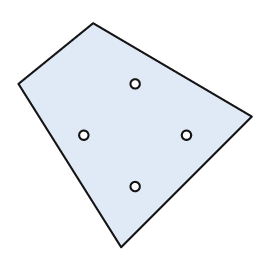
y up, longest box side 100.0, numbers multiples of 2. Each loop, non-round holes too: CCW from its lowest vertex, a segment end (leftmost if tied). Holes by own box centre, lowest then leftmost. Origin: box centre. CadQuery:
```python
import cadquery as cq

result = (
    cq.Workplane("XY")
    .moveTo(-6.0, -48.0)
    .lineTo(50.0, 8.0)
    .lineTo(-18.0, 48.0)
    .lineTo(-50.0, 22.0)
    .close()
    .moveTo(0.0, -22.0)
    .circle(2.0)
    .moveTo(-22.0, 0.0)
    .circle(2.0)
    .moveTo(22.0, 0.0)
    .circle(2.0)
    .moveTo(0.0, 22.0)
    .circle(2.0)
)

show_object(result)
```